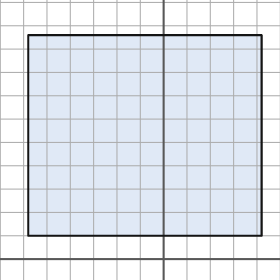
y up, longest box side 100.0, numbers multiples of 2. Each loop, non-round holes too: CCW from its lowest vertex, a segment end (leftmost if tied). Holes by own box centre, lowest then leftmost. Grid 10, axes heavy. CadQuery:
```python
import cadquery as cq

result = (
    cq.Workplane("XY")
    .moveTo(-58.0, 10.0)
    .lineTo(42.0, 10.0)
    .lineTo(42.0, 96.0)
    .lineTo(-58.0, 96.0)
    .close()
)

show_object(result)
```